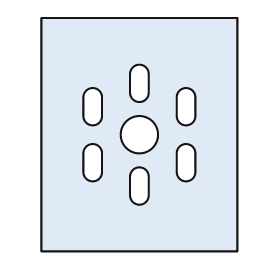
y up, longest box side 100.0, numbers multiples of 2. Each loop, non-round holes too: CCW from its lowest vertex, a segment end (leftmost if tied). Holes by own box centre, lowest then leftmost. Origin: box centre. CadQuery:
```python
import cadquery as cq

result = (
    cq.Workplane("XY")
    .moveTo(-42.0, -50.0)
    .lineTo(42.0, -50.0)
    .lineTo(42.0, 50.0)
    .lineTo(-42.0, 50.0)
    .close()
    .moveTo(-4.0, -26.0)
    .threePointArc((0.0, -30.0), (4.0, -26.0))
    .lineTo(4.0, -18.0)
    .threePointArc((0.0, -14.0), (-4.0, -18.0))
    .close()
    .moveTo(-24.0, -16.0)
    .threePointArc((-20.0, -20.0), (-16.0, -16.0))
    .lineTo(-16.0, -8.0)
    .threePointArc((-20.0, -4.0), (-24.0, -8.0))
    .close()
    .moveTo(16.0, -16.0)
    .threePointArc((20.0, -20.0), (24.0, -16.0))
    .lineTo(24.0, -8.0)
    .threePointArc((20.0, -4.0), (16.0, -8.0))
    .close()
    .moveTo(0.0, 0.0)
    .circle(8.0)
    .moveTo(-24.0, 8.0)
    .threePointArc((-20.0, 4.0), (-16.0, 8.0))
    .lineTo(-16.0, 16.0)
    .threePointArc((-20.0, 20.0), (-24.0, 16.0))
    .close()
    .moveTo(16.0, 8.0)
    .threePointArc((20.0, 4.0), (24.0, 8.0))
    .lineTo(24.0, 16.0)
    .threePointArc((20.0, 20.0), (16.0, 16.0))
    .close()
    .moveTo(-4.0, 18.0)
    .threePointArc((0.0, 14.0), (4.0, 18.0))
    .lineTo(4.0, 26.0)
    .threePointArc((0.0, 30.0), (-4.0, 26.0))
    .close()
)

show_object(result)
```